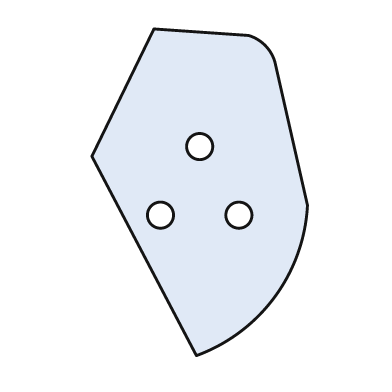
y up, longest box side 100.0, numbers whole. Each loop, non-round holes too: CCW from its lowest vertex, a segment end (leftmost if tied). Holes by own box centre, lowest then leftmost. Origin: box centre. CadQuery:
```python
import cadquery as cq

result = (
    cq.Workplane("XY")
    .moveTo(-1.0, -50.0)
    .threePointArc((23.0, -32.0), (33.0, -4.0))
    .lineTo(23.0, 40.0)
    .threePointArc((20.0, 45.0), (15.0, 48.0))
    .lineTo(-14.0, 50.0)
    .lineTo(-33.0, 11.0)
    .close()
    .moveTo(-12.0, -7.0)
    .circle(4.0)
    .moveTo(12.0, -7.0)
    .circle(4.0)
    .moveTo(0.0, 14.0)
    .circle(4.0)
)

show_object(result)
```